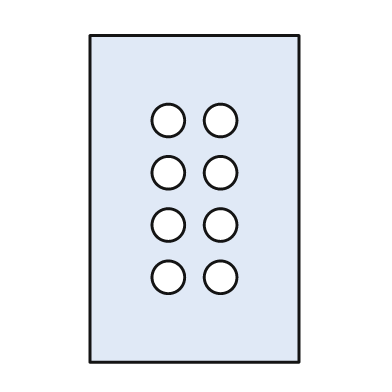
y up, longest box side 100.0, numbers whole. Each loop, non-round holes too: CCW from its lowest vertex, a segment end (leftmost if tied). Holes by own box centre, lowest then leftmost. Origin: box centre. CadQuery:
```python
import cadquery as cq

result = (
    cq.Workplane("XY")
    .moveTo(-32.0, -50.0)
    .lineTo(32.0, -50.0)
    .lineTo(32.0, 50.0)
    .lineTo(-32.0, 50.0)
    .close()
    .moveTo(-8.0, -24.0)
    .circle(5.0)
    .moveTo(8.0, -24.0)
    .circle(5.0)
    .moveTo(-8.0, -8.0)
    .circle(5.0)
    .moveTo(8.0, -8.0)
    .circle(5.0)
    .moveTo(-8.0, 8.0)
    .circle(5.0)
    .moveTo(8.0, 8.0)
    .circle(5.0)
    .moveTo(-8.0, 24.0)
    .circle(5.0)
    .moveTo(8.0, 24.0)
    .circle(5.0)
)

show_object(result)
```